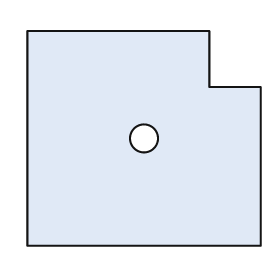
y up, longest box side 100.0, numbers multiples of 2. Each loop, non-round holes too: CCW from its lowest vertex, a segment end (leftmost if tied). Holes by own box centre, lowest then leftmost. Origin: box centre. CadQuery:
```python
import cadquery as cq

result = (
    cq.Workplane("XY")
    .moveTo(-50.0, -46.0)
    .lineTo(50.0, -46.0)
    .lineTo(50.0, 22.0)
    .lineTo(28.0, 22.0)
    .lineTo(28.0, 46.0)
    .lineTo(-50.0, 46.0)
    .close()
    .moveTo(0.0, 0.0)
    .circle(6.0)
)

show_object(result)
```